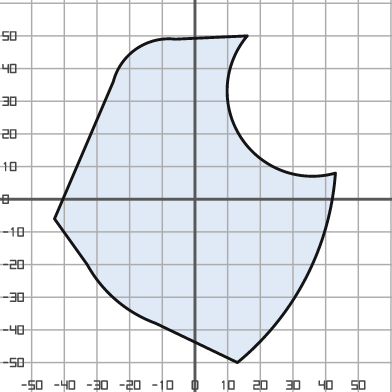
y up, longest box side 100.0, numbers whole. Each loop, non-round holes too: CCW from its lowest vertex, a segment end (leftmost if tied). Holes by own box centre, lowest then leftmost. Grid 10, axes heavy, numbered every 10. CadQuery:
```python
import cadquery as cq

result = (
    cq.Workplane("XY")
    .moveTo(13.0, -50.0)
    .threePointArc((34.0, -24.0), (43.0, 8.0))
    .threePointArc((14.0, 19.0), (16.0, 50.0))
    .lineTo(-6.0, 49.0)
    .threePointArc((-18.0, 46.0), (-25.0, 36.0))
    .lineTo(-43.0, -6.0)
    .lineTo(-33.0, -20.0)
    .threePointArc((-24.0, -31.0), (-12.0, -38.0))
    .close()
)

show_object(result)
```